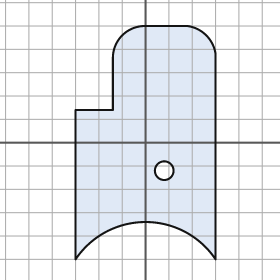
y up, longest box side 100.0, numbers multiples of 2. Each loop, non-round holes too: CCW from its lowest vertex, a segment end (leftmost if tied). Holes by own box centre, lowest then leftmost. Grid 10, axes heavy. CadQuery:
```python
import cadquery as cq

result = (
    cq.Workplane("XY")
    .moveTo(-30.0, -50.0)
    .threePointArc((0.0, -34.0), (30.0, -50.0))
    .lineTo(30.0, 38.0)
    .threePointArc((26.0, 46.0), (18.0, 50.0))
    .lineTo(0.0, 50.0)
    .threePointArc((-10.0, 46.0), (-14.0, 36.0))
    .lineTo(-14.0, 14.0)
    .lineTo(-30.0, 14.0)
    .close()
    .moveTo(8.0, -12.0)
    .circle(4.0)
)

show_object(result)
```